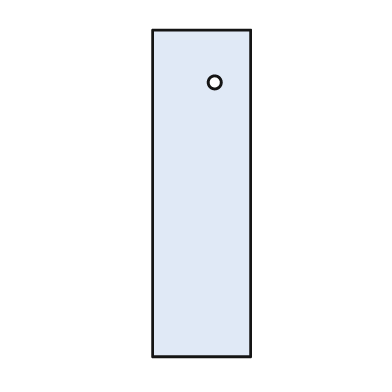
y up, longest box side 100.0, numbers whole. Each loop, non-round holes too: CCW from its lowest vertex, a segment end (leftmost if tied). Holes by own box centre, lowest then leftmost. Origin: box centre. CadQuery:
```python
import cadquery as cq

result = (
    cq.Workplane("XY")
    .moveTo(-15.0, -50.0)
    .lineTo(15.0, -50.0)
    .lineTo(15.0, 50.0)
    .lineTo(-15.0, 50.0)
    .close()
    .moveTo(4.0, 34.0)
    .circle(2.0)
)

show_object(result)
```